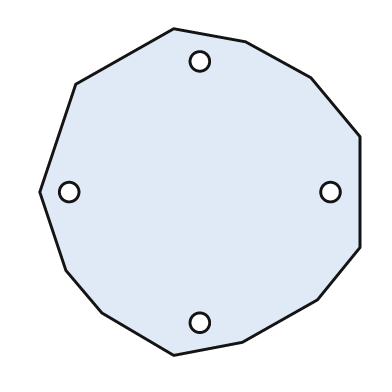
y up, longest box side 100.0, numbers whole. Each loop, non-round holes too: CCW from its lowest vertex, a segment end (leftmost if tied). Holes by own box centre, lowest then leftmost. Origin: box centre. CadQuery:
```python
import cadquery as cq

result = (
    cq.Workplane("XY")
    .moveTo(-8.0, -50.0)
    .lineTo(13.0, -46.0)
    .lineTo(36.0, -33.0)
    .lineTo(49.0, -17.0)
    .lineTo(49.0, 17.0)
    .lineTo(34.0, 35.0)
    .lineTo(14.0, 46.0)
    .lineTo(-8.0, 50.0)
    .lineTo(-38.0, 33.0)
    .lineTo(-49.0, 0.0)
    .lineTo(-41.0, -24.0)
    .lineTo(-30.0, -37.0)
    .close()
    .moveTo(0.0, -40.0)
    .circle(3.0)
    .moveTo(-40.0, 0.0)
    .circle(3.0)
    .moveTo(40.0, 0.0)
    .circle(3.0)
    .moveTo(0.0, 40.0)
    .circle(3.0)
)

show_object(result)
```